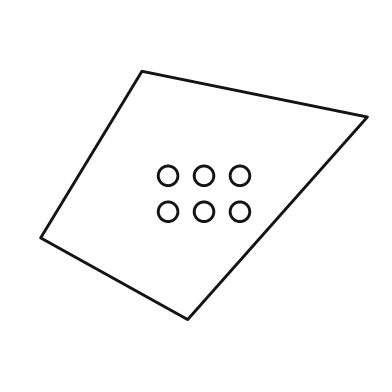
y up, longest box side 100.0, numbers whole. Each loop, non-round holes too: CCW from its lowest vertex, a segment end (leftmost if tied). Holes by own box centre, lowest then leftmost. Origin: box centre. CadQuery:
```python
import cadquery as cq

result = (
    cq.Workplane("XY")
    .moveTo(-5.0, -38.0)
    .lineTo(50.0, 24.0)
    .lineTo(-19.0, 38.0)
    .lineTo(-50.0, -13.0)
    .close()
    .moveTo(-11.0, -5.0)
    .circle(3.0)
    .moveTo(0.0, -5.0)
    .circle(3.0)
    .moveTo(11.0, -5.0)
    .circle(3.0)
    .moveTo(-11.0, 6.0)
    .circle(3.0)
    .moveTo(0.0, 6.0)
    .circle(3.0)
    .moveTo(11.0, 6.0)
    .circle(3.0)
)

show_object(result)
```